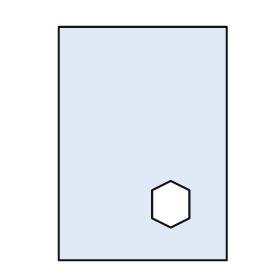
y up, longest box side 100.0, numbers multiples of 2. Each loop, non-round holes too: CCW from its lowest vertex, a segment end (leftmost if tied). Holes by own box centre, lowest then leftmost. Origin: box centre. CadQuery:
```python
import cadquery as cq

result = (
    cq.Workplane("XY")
    .moveTo(-36.0, -50.0)
    .lineTo(36.0, -50.0)
    .lineTo(36.0, 50.0)
    .lineTo(-36.0, 50.0)
    .close()
    .moveTo(12.0, -36.0)
    .lineTo(20.0, -32.0)
    .lineTo(20.0, -20.0)
    .lineTo(12.0, -16.0)
    .lineTo(4.0, -20.0)
    .lineTo(4.0, -32.0)
    .close()
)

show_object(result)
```